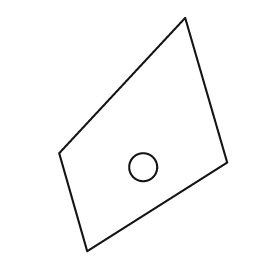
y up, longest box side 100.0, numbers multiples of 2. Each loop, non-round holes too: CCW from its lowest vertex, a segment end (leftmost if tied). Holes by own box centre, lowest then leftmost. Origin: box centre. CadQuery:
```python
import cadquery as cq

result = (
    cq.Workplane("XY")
    .moveTo(-24.0, -50.0)
    .lineTo(36.0, -12.0)
    .lineTo(18.0, 50.0)
    .lineTo(-36.0, -8.0)
    .close()
    .moveTo(0.0, -14.0)
    .circle(6.0)
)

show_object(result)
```